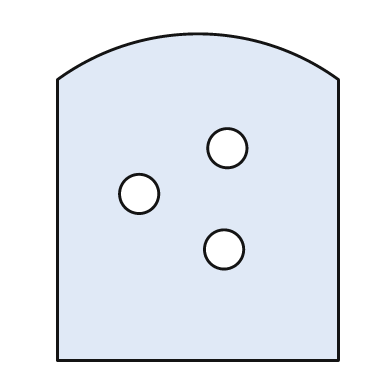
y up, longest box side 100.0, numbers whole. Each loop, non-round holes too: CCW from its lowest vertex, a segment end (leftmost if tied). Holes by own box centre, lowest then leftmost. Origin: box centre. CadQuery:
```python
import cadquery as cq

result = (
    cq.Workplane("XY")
    .moveTo(-43.0, -50.0)
    .lineTo(43.0, -50.0)
    .lineTo(43.0, 36.0)
    .threePointArc((0.0, 50.0), (-43.0, 36.0))
    .close()
    .moveTo(8.0, -16.0)
    .circle(6.0)
    .moveTo(-18.0, 1.0)
    .circle(6.0)
    .moveTo(9.0, 15.0)
    .circle(6.0)
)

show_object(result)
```